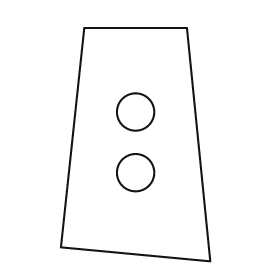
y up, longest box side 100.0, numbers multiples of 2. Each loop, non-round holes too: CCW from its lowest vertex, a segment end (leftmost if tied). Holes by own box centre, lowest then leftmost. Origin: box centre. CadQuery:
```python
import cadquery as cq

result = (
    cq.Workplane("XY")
    .moveTo(32.0, -50.0)
    .lineTo(22.0, 50.0)
    .lineTo(-22.0, 50.0)
    .lineTo(-32.0, -44.0)
    .close()
    .moveTo(0.0, -12.0)
    .circle(8.0)
    .moveTo(0.0, 14.0)
    .circle(8.0)
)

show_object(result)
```